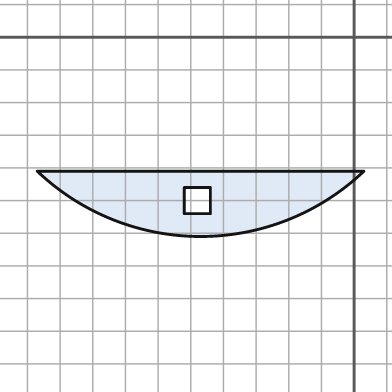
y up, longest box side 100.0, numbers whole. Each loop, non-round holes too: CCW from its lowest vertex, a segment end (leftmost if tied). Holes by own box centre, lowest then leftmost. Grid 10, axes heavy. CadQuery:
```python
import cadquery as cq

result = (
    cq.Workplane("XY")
    .moveTo(-97.0, -41.0)
    .threePointArc((-47.0, -61.0), (3.0, -41.0))
    .close()
    .moveTo(-52.0, -54.0)
    .lineTo(-44.0, -54.0)
    .lineTo(-44.0, -46.0)
    .lineTo(-52.0, -46.0)
    .close()
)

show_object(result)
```